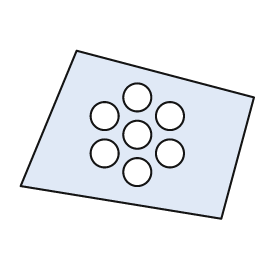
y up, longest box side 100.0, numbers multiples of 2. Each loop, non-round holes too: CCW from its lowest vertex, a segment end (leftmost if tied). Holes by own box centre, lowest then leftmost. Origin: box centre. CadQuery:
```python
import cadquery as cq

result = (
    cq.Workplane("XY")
    .moveTo(36.0, -36.0)
    .lineTo(50.0, 16.0)
    .lineTo(-26.0, 36.0)
    .lineTo(-50.0, -22.0)
    .close()
    .moveTo(0.0, -16.0)
    .circle(6.0)
    .moveTo(-14.0, -8.0)
    .circle(6.0)
    .moveTo(14.0, -8.0)
    .circle(6.0)
    .moveTo(0.0, 0.0)
    .circle(6.0)
    .moveTo(-14.0, 8.0)
    .circle(6.0)
    .moveTo(14.0, 8.0)
    .circle(6.0)
    .moveTo(0.0, 16.0)
    .circle(6.0)
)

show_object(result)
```